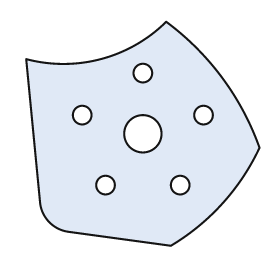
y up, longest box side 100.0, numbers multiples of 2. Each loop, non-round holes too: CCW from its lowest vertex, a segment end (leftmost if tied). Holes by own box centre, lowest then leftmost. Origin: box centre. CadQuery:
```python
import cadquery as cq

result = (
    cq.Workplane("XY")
    .moveTo(12.0, -48.0)
    .threePointArc((34.0, -30.0), (50.0, -6.0))
    .threePointArc((34.0, 24.0), (10.0, 48.0))
    .threePointArc((-18.0, 32.0), (-50.0, 32.0))
    .lineTo(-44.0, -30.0)
    .threePointArc((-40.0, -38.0), (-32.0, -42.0))
    .close()
    .moveTo(-16.0, -22.0)
    .circle(4.0)
    .moveTo(16.0, -22.0)
    .circle(4.0)
    .moveTo(0.0, 0.0)
    .circle(8.0)
    .moveTo(-26.0, 8.0)
    .circle(4.0)
    .moveTo(26.0, 8.0)
    .circle(4.0)
    .moveTo(0.0, 26.0)
    .circle(4.0)
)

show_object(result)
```